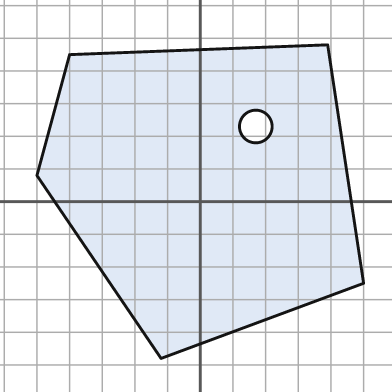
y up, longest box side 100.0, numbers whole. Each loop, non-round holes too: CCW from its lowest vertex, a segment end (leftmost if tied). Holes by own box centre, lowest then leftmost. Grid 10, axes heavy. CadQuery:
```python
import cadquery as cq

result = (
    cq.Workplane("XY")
    .moveTo(-12.0, -48.0)
    .lineTo(50.0, -25.0)
    .lineTo(39.0, 48.0)
    .lineTo(-40.0, 45.0)
    .lineTo(-50.0, 8.0)
    .close()
    .moveTo(17.0, 23.0)
    .circle(5.0)
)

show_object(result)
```